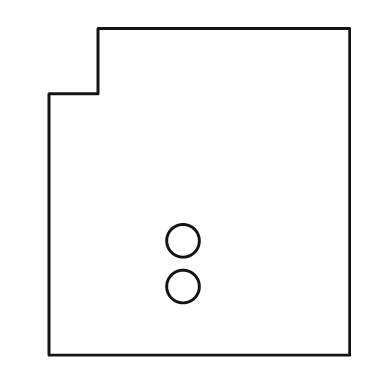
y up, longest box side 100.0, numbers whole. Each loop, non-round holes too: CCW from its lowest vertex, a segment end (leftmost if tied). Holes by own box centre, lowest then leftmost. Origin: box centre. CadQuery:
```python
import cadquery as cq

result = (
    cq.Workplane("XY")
    .moveTo(-46.0, -50.0)
    .lineTo(46.0, -50.0)
    .lineTo(46.0, 50.0)
    .lineTo(-31.0, 50.0)
    .lineTo(-31.0, 30.0)
    .lineTo(-46.0, 30.0)
    .close()
    .moveTo(-5.0, -29.0)
    .circle(5.0)
    .moveTo(-5.0, -15.0)
    .circle(5.0)
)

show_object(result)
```